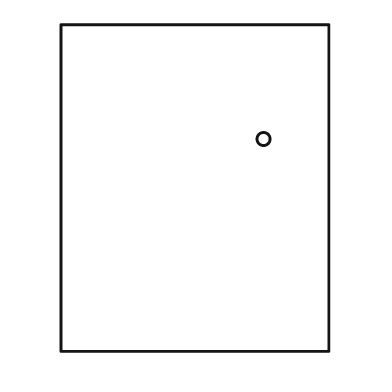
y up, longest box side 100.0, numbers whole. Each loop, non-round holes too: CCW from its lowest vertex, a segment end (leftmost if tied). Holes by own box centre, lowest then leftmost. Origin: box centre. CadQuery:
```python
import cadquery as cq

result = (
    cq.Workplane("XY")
    .moveTo(-41.0, -50.0)
    .lineTo(41.0, -50.0)
    .lineTo(41.0, 50.0)
    .lineTo(-41.0, 50.0)
    .close()
    .moveTo(21.0, 15.0)
    .circle(2.0)
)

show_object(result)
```